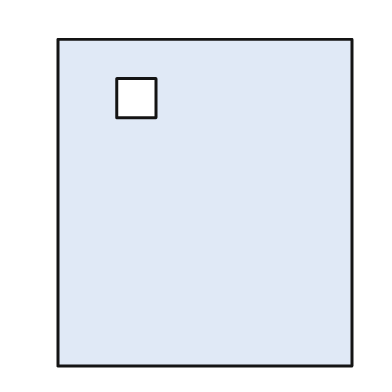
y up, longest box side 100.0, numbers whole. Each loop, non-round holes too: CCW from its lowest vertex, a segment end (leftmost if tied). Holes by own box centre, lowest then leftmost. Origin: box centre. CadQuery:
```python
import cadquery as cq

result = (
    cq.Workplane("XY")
    .moveTo(-45.0, -50.0)
    .lineTo(45.0, -50.0)
    .lineTo(45.0, 50.0)
    .lineTo(-45.0, 50.0)
    .close()
    .moveTo(-27.0, 26.0)
    .lineTo(-15.0, 26.0)
    .lineTo(-15.0, 38.0)
    .lineTo(-27.0, 38.0)
    .close()
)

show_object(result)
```